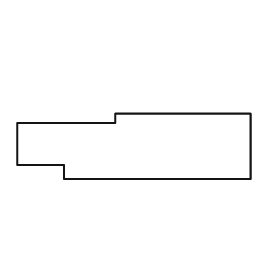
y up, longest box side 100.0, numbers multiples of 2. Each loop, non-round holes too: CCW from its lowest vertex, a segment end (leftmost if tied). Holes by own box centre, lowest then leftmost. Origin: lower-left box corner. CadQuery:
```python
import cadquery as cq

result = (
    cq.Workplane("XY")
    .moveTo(20.0, 0.0)
    .lineTo(100.0, 0.0)
    .lineTo(100.0, 28.0)
    .lineTo(42.0, 28.0)
    .lineTo(42.0, 24.0)
    .lineTo(0.0, 24.0)
    .lineTo(0.0, 6.0)
    .lineTo(20.0, 6.0)
    .close()
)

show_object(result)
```